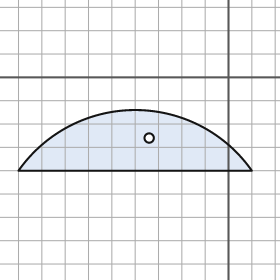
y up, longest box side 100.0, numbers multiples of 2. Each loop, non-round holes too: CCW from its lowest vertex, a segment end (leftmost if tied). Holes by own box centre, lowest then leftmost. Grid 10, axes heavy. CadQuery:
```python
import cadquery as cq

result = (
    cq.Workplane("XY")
    .moveTo(-90.0, -40.0)
    .lineTo(10.0, -40.0)
    .threePointArc((-40.0, -14.0), (-90.0, -40.0))
    .close()
    .moveTo(-34.0, -26.0)
    .circle(2.0)
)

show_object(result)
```